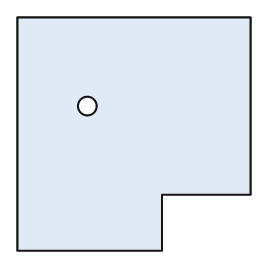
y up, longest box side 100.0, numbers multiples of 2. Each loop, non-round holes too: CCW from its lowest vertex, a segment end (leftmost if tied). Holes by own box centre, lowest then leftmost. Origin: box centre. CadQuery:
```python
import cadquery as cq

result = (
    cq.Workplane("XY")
    .moveTo(-50.0, -50.0)
    .lineTo(12.0, -50.0)
    .lineTo(12.0, -26.0)
    .lineTo(50.0, -26.0)
    .lineTo(50.0, 50.0)
    .lineTo(-50.0, 50.0)
    .close()
    .moveTo(-20.0, 12.0)
    .circle(4.0)
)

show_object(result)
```